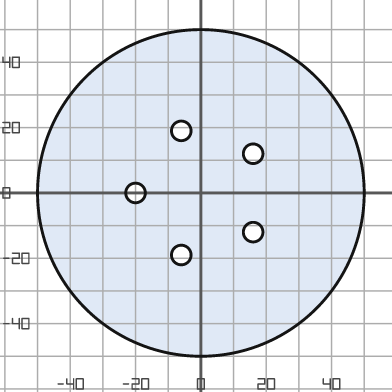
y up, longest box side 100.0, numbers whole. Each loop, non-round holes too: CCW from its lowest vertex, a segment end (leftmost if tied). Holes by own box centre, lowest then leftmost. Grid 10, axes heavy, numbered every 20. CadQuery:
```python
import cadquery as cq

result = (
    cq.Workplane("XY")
    .moveTo(0.0, 0.0)
    .circle(50.0)
    .moveTo(-6.0, -19.0)
    .circle(3.0)
    .moveTo(16.0, -12.0)
    .circle(3.0)
    .moveTo(-20.0, 0.0)
    .circle(3.0)
    .moveTo(16.0, 12.0)
    .circle(3.0)
    .moveTo(-6.0, 19.0)
    .circle(3.0)
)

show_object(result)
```